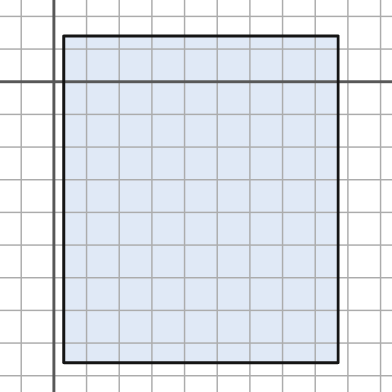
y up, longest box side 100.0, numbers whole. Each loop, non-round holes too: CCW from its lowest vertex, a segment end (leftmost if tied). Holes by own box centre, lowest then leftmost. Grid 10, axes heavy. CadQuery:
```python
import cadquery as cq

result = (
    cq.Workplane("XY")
    .moveTo(3.0, -86.0)
    .lineTo(87.0, -86.0)
    .lineTo(87.0, 14.0)
    .lineTo(3.0, 14.0)
    .close()
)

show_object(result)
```